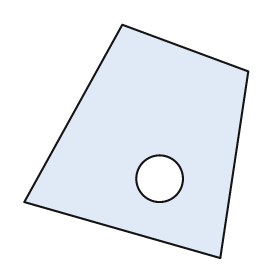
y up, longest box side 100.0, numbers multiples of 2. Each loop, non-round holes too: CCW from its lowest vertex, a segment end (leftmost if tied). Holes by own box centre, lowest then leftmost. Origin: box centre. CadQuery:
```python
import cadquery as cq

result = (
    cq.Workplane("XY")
    .moveTo(36.0, -50.0)
    .lineTo(48.0, 30.0)
    .lineTo(-6.0, 50.0)
    .lineTo(-48.0, -26.0)
    .close()
    .moveTo(10.0, -16.0)
    .circle(10.0)
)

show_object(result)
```